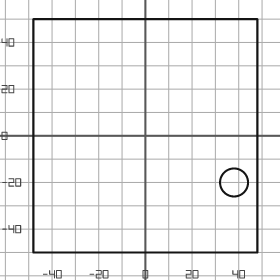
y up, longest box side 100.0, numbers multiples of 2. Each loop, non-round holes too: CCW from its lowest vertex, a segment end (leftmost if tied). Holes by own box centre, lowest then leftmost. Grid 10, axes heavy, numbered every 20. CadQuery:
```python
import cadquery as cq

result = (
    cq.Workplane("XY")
    .moveTo(-48.0, -50.0)
    .lineTo(48.0, -50.0)
    .lineTo(48.0, 50.0)
    .lineTo(-48.0, 50.0)
    .close()
    .moveTo(38.0, -20.0)
    .circle(6.0)
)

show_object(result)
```